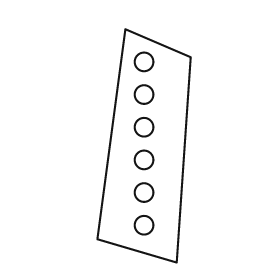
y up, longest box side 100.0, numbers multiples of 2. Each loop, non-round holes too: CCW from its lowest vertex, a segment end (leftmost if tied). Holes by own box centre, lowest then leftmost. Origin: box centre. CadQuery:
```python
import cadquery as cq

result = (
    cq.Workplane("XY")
    .moveTo(14.0, -50.0)
    .lineTo(20.0, 38.0)
    .lineTo(-8.0, 50.0)
    .lineTo(-20.0, -40.0)
    .close()
    .moveTo(0.0, -34.0)
    .circle(4.0)
    .moveTo(0.0, -20.0)
    .circle(4.0)
    .moveTo(0.0, -6.0)
    .circle(4.0)
    .moveTo(0.0, 8.0)
    .circle(4.0)
    .moveTo(0.0, 22.0)
    .circle(4.0)
    .moveTo(0.0, 36.0)
    .circle(4.0)
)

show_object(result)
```